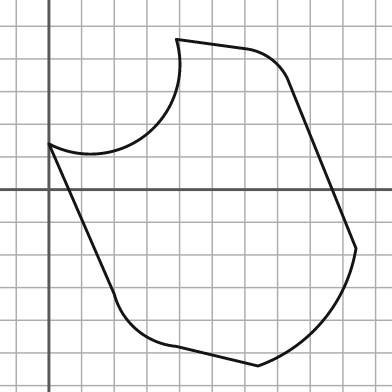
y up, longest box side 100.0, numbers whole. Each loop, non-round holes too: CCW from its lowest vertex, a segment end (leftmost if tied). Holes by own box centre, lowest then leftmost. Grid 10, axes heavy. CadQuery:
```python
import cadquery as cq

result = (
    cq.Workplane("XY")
    .moveTo(64.0, -54.0)
    .threePointArc((84.0, -40.0), (94.0, -18.0))
    .lineTo(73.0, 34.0)
    .threePointArc((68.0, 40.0), (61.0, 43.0))
    .lineTo(39.0, 46.0)
    .threePointArc((30.0, 17.0), (0.0, 14.0))
    .lineTo(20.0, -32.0)
    .threePointArc((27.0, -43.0), (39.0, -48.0))
    .close()
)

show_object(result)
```